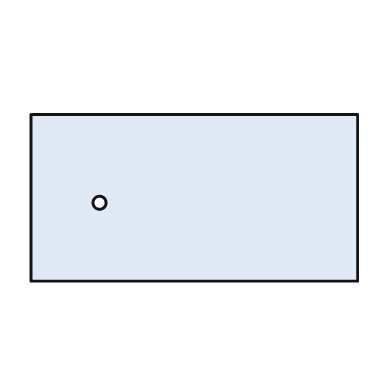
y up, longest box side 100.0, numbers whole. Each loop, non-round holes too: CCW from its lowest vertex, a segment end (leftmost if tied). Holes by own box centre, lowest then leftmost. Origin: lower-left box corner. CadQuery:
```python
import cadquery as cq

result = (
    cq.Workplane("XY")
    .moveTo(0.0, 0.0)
    .lineTo(100.0, 0.0)
    .lineTo(100.0, 51.0)
    .lineTo(0.0, 51.0)
    .close()
    .moveTo(21.0, 24.0)
    .circle(2.0)
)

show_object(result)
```